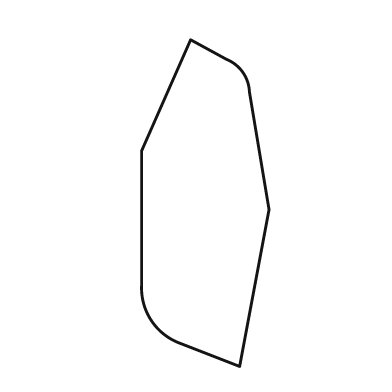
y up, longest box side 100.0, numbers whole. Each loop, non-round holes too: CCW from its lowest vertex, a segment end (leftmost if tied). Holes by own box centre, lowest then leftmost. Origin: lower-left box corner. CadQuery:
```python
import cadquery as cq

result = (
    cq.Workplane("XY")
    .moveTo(30.0, 0.0)
    .lineTo(39.0, 48.0)
    .lineTo(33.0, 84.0)
    .threePointArc((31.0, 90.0), (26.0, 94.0))
    .lineTo(15.0, 100.0)
    .lineTo(0.0, 66.0)
    .lineTo(0.0, 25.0)
    .threePointArc((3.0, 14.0), (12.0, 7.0))
    .close()
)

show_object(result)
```